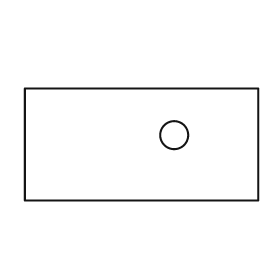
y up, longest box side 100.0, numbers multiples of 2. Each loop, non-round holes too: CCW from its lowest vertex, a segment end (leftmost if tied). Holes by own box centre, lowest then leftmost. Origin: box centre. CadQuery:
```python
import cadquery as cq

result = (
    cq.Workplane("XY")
    .moveTo(-50.0, -24.0)
    .lineTo(50.0, -24.0)
    .lineTo(50.0, 24.0)
    .lineTo(-50.0, 24.0)
    .close()
    .moveTo(14.0, 4.0)
    .circle(6.0)
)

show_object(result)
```